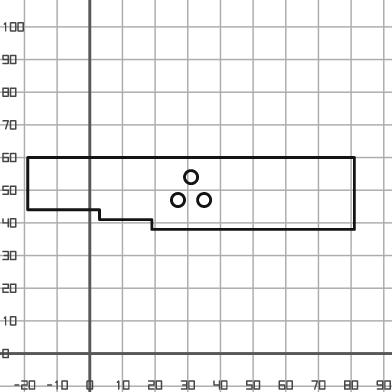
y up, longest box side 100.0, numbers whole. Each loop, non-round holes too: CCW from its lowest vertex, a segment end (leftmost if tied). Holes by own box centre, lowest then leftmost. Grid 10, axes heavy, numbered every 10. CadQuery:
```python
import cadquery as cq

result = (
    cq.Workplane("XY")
    .moveTo(19.0, 38.0)
    .lineTo(81.0, 38.0)
    .lineTo(81.0, 60.0)
    .lineTo(-19.0, 60.0)
    .lineTo(-19.0, 44.0)
    .lineTo(3.0, 44.0)
    .lineTo(3.0, 41.0)
    .lineTo(19.0, 41.0)
    .close()
    .moveTo(27.0, 47.0)
    .circle(2.0)
    .moveTo(35.0, 47.0)
    .circle(2.0)
    .moveTo(31.0, 54.0)
    .circle(2.0)
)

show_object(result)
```